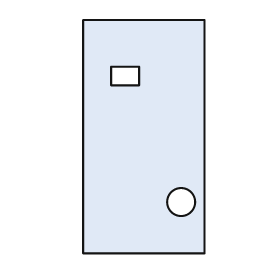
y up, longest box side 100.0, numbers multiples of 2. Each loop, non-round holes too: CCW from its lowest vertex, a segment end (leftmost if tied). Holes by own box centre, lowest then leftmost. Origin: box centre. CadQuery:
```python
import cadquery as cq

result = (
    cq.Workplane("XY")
    .moveTo(-26.0, -50.0)
    .lineTo(26.0, -50.0)
    .lineTo(26.0, 50.0)
    .lineTo(-26.0, 50.0)
    .close()
    .moveTo(16.0, -28.0)
    .circle(6.0)
    .moveTo(-14.0, 22.0)
    .lineTo(-2.0, 22.0)
    .lineTo(-2.0, 30.0)
    .lineTo(-14.0, 30.0)
    .close()
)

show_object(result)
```